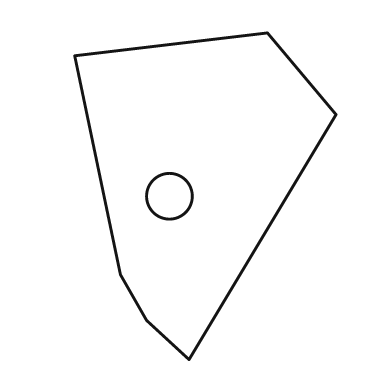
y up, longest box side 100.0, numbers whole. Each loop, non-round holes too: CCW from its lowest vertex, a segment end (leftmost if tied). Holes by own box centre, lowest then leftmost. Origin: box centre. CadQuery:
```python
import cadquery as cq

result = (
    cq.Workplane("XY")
    .moveTo(-5.0, -50.0)
    .lineTo(40.0, 25.0)
    .lineTo(19.0, 50.0)
    .lineTo(-40.0, 43.0)
    .lineTo(-26.0, -24.0)
    .lineTo(-18.0, -38.0)
    .close()
    .moveTo(-11.0, 0.0)
    .circle(7.0)
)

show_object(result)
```